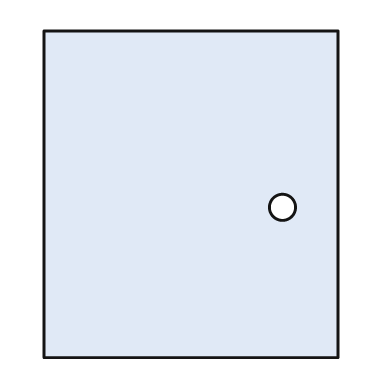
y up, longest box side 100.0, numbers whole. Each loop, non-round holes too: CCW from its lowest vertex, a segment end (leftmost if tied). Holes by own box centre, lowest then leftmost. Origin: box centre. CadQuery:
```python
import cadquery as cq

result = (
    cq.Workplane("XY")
    .moveTo(-45.0, -50.0)
    .lineTo(45.0, -50.0)
    .lineTo(45.0, 50.0)
    .lineTo(-45.0, 50.0)
    .close()
    .moveTo(28.0, -4.0)
    .circle(4.0)
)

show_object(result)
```